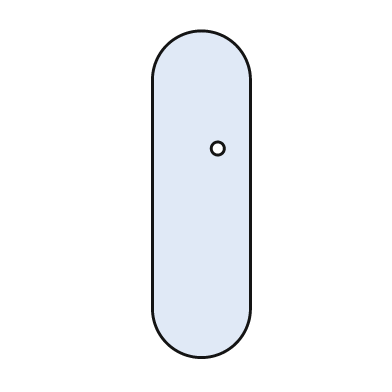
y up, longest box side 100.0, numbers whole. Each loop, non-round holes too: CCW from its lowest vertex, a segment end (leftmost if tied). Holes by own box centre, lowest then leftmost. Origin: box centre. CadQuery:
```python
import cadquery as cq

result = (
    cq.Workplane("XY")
    .moveTo(-15.0, -35.0)
    .threePointArc((0.0, -50.0), (15.0, -35.0))
    .lineTo(15.0, 35.0)
    .threePointArc((0.0, 50.0), (-15.0, 35.0))
    .close()
    .moveTo(5.0, 14.0)
    .circle(2.0)
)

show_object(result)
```